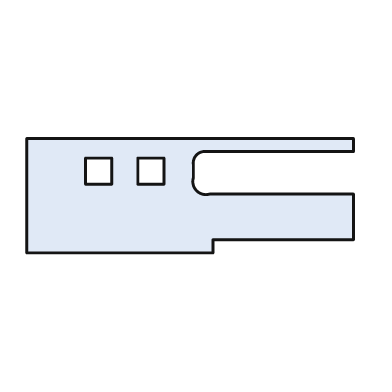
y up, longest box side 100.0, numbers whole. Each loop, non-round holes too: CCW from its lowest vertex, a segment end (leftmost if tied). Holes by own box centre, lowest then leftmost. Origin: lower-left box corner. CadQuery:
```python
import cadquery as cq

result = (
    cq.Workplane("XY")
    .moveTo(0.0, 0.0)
    .lineTo(57.0, 0.0)
    .lineTo(57.0, 4.0)
    .lineTo(100.0, 4.0)
    .lineTo(100.0, 18.0)
    .lineTo(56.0, 18.0)
    .threePointArc((52.0, 19.0), (51.0, 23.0))
    .lineTo(51.0, 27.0)
    .threePointArc((52.0, 30.0), (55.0, 31.0))
    .lineTo(100.0, 31.0)
    .lineTo(100.0, 35.0)
    .lineTo(0.0, 35.0)
    .close()
    .moveTo(18.0, 21.0)
    .lineTo(26.0, 21.0)
    .lineTo(26.0, 29.0)
    .lineTo(18.0, 29.0)
    .close()
    .moveTo(34.0, 21.0)
    .lineTo(42.0, 21.0)
    .lineTo(42.0, 29.0)
    .lineTo(34.0, 29.0)
    .close()
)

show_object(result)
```